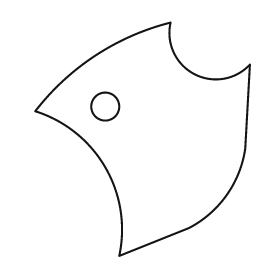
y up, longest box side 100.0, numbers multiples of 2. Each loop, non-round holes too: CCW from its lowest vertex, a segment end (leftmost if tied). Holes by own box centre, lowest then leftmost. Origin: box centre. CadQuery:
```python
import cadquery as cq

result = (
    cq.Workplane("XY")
    .moveTo(-10.0, -50.0)
    .lineTo(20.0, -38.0)
    .threePointArc((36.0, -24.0), (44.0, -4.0))
    .lineTo(46.0, 32.0)
    .threePointArc((22.0, 28.0), (12.0, 50.0))
    .threePointArc((-20.0, 36.0), (-46.0, 12.0))
    .threePointArc((-16.0, -12.0), (-10.0, -50.0))
    .close()
    .moveTo(-16.0, 14.0)
    .circle(6.0)
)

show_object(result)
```